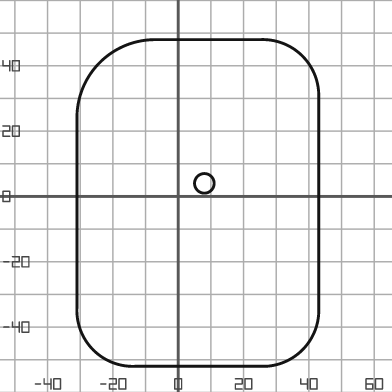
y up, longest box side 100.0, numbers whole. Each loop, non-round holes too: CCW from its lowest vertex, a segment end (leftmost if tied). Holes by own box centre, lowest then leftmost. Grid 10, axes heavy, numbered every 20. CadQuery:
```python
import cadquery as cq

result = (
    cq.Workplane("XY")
    .moveTo(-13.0, -52.0)
    .lineTo(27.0, -52.0)
    .threePointArc((38.0, -47.0), (43.0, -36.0))
    .lineTo(43.0, 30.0)
    .threePointArc((38.0, 43.0), (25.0, 48.0))
    .lineTo(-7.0, 48.0)
    .threePointArc((-24.0, 41.0), (-31.0, 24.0))
    .lineTo(-31.0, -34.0)
    .threePointArc((-26.0, -47.0), (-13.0, -52.0))
    .close()
    .moveTo(8.0, 4.0)
    .circle(3.0)
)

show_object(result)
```